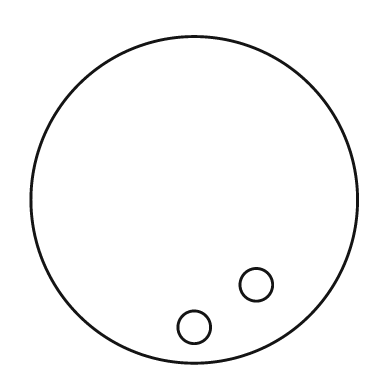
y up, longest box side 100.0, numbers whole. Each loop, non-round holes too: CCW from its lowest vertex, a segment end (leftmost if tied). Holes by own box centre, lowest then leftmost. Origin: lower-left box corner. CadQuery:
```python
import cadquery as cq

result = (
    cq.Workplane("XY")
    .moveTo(50.0, 50.0)
    .circle(50.0)
    .moveTo(50.0, 11.0)
    .circle(5.0)
    .moveTo(69.0, 24.0)
    .circle(5.0)
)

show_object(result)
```